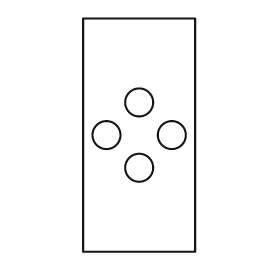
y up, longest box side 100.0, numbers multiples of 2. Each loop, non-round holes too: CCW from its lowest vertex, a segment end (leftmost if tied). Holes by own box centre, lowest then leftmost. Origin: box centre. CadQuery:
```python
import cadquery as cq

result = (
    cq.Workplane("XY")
    .moveTo(-24.0, -50.0)
    .lineTo(24.0, -50.0)
    .lineTo(24.0, 50.0)
    .lineTo(-24.0, 50.0)
    .close()
    .moveTo(0.0, -14.0)
    .circle(6.0)
    .moveTo(-14.0, 0.0)
    .circle(6.0)
    .moveTo(14.0, 0.0)
    .circle(6.0)
    .moveTo(0.0, 14.0)
    .circle(6.0)
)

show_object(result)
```